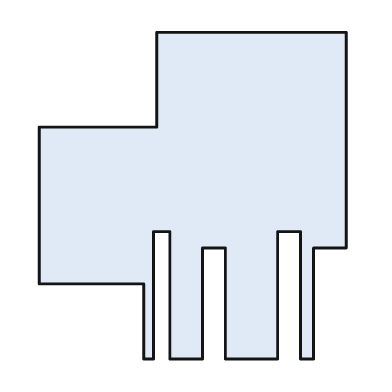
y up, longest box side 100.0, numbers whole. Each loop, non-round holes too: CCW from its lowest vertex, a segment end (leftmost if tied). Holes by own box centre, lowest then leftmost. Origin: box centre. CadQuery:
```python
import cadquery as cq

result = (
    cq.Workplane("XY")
    .moveTo(-15.0, -50.0)
    .lineTo(-12.0, -50.0)
    .lineTo(-12.0, -11.0)
    .lineTo(-7.0, -11.0)
    .lineTo(-7.0, -50.0)
    .lineTo(3.0, -50.0)
    .lineTo(3.0, -16.0)
    .lineTo(10.0, -16.0)
    .lineTo(10.0, -50.0)
    .lineTo(26.0, -50.0)
    .lineTo(26.0, -11.0)
    .lineTo(33.0, -11.0)
    .lineTo(33.0, -50.0)
    .lineTo(37.0, -50.0)
    .lineTo(37.0, -16.0)
    .lineTo(47.0, -16.0)
    .lineTo(47.0, 50.0)
    .lineTo(-11.0, 50.0)
    .lineTo(-11.0, 21.0)
    .lineTo(-47.0, 21.0)
    .lineTo(-47.0, -27.0)
    .lineTo(-15.0, -27.0)
    .close()
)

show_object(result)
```